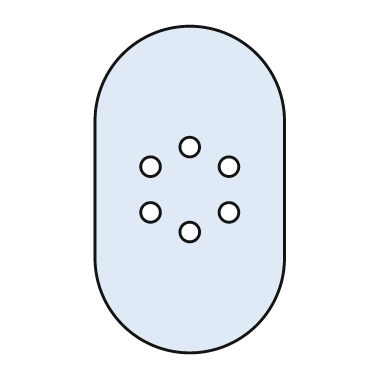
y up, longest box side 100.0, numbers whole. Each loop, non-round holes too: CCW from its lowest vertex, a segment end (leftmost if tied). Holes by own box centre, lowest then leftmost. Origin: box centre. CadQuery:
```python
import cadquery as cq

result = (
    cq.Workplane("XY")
    .moveTo(-29.0, -21.0)
    .threePointArc((0.0, -50.0), (29.0, -21.0))
    .lineTo(29.0, 21.0)
    .threePointArc((0.0, 50.0), (-29.0, 21.0))
    .close()
    .moveTo(0.0, -13.0)
    .circle(3.0)
    .moveTo(-12.0, -7.0)
    .circle(3.0)
    .moveTo(12.0, -7.0)
    .circle(3.0)
    .moveTo(-12.0, 7.0)
    .circle(3.0)
    .moveTo(12.0, 7.0)
    .circle(3.0)
    .moveTo(0.0, 13.0)
    .circle(3.0)
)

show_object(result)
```